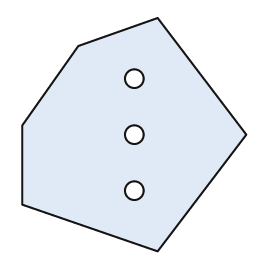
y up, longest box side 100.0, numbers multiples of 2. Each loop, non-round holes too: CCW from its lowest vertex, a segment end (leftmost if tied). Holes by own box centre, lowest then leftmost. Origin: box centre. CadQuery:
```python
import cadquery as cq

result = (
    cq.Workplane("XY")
    .moveTo(10.0, -50.0)
    .lineTo(48.0, 0.0)
    .lineTo(10.0, 50.0)
    .lineTo(-24.0, 38.0)
    .lineTo(-48.0, 4.0)
    .lineTo(-48.0, -30.0)
    .close()
    .moveTo(0.0, -24.0)
    .circle(4.0)
    .moveTo(0.0, 0.0)
    .circle(4.0)
    .moveTo(0.0, 24.0)
    .circle(4.0)
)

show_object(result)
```